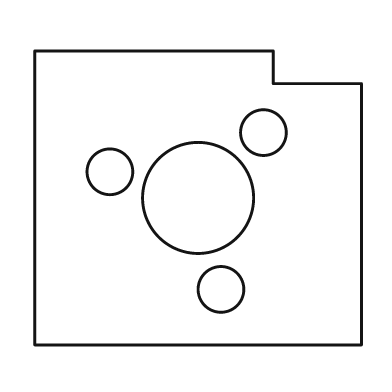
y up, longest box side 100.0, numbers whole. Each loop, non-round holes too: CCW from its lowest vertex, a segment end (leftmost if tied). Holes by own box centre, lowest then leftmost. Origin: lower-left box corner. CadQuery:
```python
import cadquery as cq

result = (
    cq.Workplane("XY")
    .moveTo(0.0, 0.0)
    .lineTo(100.0, 0.0)
    .lineTo(100.0, 80.0)
    .lineTo(73.0, 80.0)
    .lineTo(73.0, 90.0)
    .lineTo(0.0, 90.0)
    .close()
    .moveTo(57.0, 17.0)
    .circle(7.0)
    .moveTo(50.0, 45.0)
    .circle(17.0)
    .moveTo(23.0, 53.0)
    .circle(7.0)
    .moveTo(70.0, 65.0)
    .circle(7.0)
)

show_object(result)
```